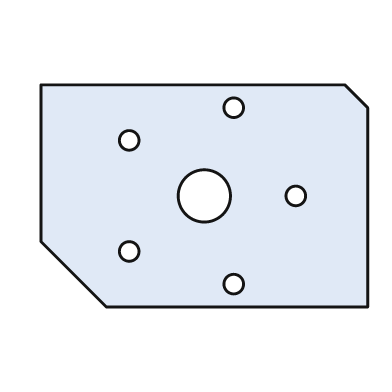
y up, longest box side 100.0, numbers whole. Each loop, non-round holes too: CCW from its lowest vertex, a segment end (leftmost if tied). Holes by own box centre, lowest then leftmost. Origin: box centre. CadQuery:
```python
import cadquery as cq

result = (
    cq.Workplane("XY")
    .moveTo(-30.0, -34.0)
    .lineTo(50.0, -34.0)
    .lineTo(50.0, 27.0)
    .lineTo(43.0, 34.0)
    .lineTo(-50.0, 34.0)
    .lineTo(-50.0, -14.0)
    .close()
    .moveTo(9.0, -27.0)
    .circle(3.0)
    .moveTo(-23.0, -17.0)
    .circle(3.0)
    .moveTo(0.0, 0.0)
    .circle(8.0)
    .moveTo(28.0, 0.0)
    .circle(3.0)
    .moveTo(-23.0, 17.0)
    .circle(3.0)
    .moveTo(9.0, 27.0)
    .circle(3.0)
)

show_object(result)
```